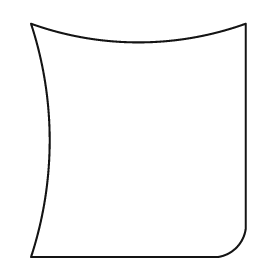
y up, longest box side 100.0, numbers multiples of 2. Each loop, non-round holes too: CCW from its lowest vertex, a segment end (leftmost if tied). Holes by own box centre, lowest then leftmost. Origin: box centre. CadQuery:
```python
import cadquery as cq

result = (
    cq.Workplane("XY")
    .moveTo(-46.0, -50.0)
    .lineTo(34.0, -50.0)
    .threePointArc((42.0, -46.0), (46.0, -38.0))
    .lineTo(46.0, 50.0)
    .threePointArc((0.0, 42.0), (-46.0, 50.0))
    .threePointArc((-38.0, 0.0), (-46.0, -50.0))
    .close()
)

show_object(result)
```